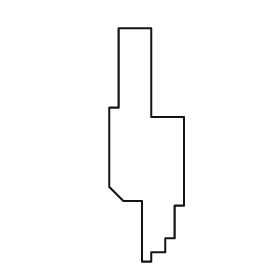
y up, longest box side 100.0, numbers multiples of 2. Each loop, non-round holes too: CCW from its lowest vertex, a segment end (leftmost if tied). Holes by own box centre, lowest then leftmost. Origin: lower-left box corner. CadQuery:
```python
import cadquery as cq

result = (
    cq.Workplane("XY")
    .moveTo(14.0, 0.0)
    .lineTo(18.0, 0.0)
    .lineTo(18.0, 4.0)
    .lineTo(24.0, 4.0)
    .lineTo(24.0, 10.0)
    .lineTo(28.0, 10.0)
    .lineTo(28.0, 24.0)
    .lineTo(32.0, 24.0)
    .lineTo(32.0, 62.0)
    .lineTo(18.0, 62.0)
    .lineTo(18.0, 100.0)
    .lineTo(4.0, 100.0)
    .lineTo(4.0, 66.0)
    .lineTo(0.0, 66.0)
    .lineTo(0.0, 32.0)
    .lineTo(6.0, 26.0)
    .lineTo(14.0, 26.0)
    .close()
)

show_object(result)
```